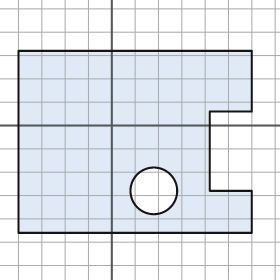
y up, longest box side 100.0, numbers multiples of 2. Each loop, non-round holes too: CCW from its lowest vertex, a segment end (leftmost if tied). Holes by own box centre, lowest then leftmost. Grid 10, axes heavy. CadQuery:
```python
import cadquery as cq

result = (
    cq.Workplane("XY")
    .moveTo(-40.0, -46.0)
    .lineTo(60.0, -46.0)
    .lineTo(60.0, -28.0)
    .lineTo(42.0, -28.0)
    .lineTo(42.0, 6.0)
    .lineTo(60.0, 6.0)
    .lineTo(60.0, 32.0)
    .lineTo(-40.0, 32.0)
    .close()
    .moveTo(18.0, -28.0)
    .circle(10.0)
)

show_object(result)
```